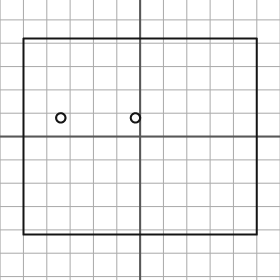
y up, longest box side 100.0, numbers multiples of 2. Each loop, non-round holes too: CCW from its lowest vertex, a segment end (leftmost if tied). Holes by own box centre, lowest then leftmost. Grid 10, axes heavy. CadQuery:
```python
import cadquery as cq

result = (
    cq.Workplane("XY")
    .moveTo(-50.0, -42.0)
    .lineTo(50.0, -42.0)
    .lineTo(50.0, 42.0)
    .lineTo(-50.0, 42.0)
    .close()
    .moveTo(-34.0, 8.0)
    .circle(2.0)
    .moveTo(-2.0, 8.0)
    .circle(2.0)
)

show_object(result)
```